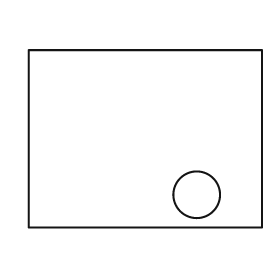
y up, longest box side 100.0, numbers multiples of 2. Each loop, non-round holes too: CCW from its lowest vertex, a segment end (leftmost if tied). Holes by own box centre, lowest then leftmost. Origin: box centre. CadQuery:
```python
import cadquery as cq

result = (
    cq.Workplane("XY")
    .moveTo(-50.0, -38.0)
    .lineTo(50.0, -38.0)
    .lineTo(50.0, 38.0)
    .lineTo(-50.0, 38.0)
    .close()
    .moveTo(22.0, -24.0)
    .circle(10.0)
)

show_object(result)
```